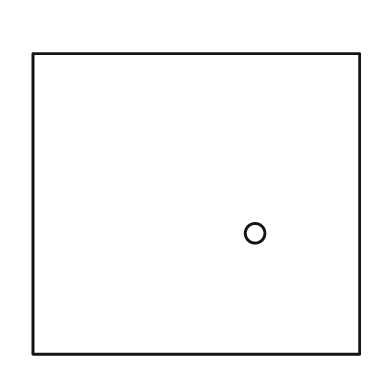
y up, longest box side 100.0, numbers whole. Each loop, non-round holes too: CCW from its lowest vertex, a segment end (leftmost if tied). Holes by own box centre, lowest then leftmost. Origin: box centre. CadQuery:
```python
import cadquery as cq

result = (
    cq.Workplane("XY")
    .moveTo(-50.0, -46.0)
    .lineTo(50.0, -46.0)
    .lineTo(50.0, 46.0)
    .lineTo(-50.0, 46.0)
    .close()
    .moveTo(18.0, -9.0)
    .circle(3.0)
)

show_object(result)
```